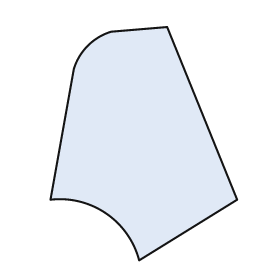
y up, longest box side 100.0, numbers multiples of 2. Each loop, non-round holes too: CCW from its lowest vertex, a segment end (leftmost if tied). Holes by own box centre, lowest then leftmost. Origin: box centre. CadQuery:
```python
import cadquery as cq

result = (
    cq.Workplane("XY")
    .moveTo(-2.0, -50.0)
    .lineTo(40.0, -24.0)
    .lineTo(10.0, 50.0)
    .lineTo(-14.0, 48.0)
    .threePointArc((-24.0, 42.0), (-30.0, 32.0))
    .lineTo(-40.0, -24.0)
    .threePointArc((-16.0, -30.0), (-2.0, -50.0))
    .close()
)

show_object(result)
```